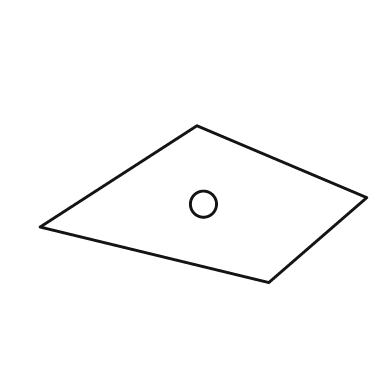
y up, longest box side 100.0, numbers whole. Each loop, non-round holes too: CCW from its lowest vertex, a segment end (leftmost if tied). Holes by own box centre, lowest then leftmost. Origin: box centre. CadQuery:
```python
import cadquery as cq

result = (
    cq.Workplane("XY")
    .moveTo(20.0, -24.0)
    .lineTo(50.0, 2.0)
    .lineTo(-2.0, 24.0)
    .lineTo(-50.0, -7.0)
    .close()
    .moveTo(0.0, 0.0)
    .circle(4.0)
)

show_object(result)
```